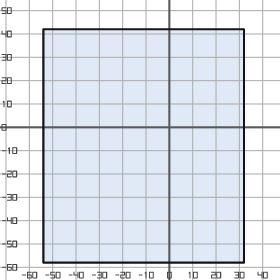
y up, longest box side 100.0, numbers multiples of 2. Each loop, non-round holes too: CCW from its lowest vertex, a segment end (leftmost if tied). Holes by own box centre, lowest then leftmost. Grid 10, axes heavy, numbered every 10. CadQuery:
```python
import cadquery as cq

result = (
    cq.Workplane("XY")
    .moveTo(-54.0, -58.0)
    .lineTo(32.0, -58.0)
    .lineTo(32.0, 42.0)
    .lineTo(-54.0, 42.0)
    .close()
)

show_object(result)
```